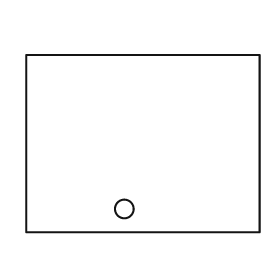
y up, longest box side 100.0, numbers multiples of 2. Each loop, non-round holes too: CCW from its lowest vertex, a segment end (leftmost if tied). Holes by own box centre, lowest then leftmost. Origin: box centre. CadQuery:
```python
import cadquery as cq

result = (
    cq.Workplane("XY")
    .moveTo(-50.0, -38.0)
    .lineTo(50.0, -38.0)
    .lineTo(50.0, 38.0)
    .lineTo(-50.0, 38.0)
    .close()
    .moveTo(-8.0, -28.0)
    .circle(4.0)
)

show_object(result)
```